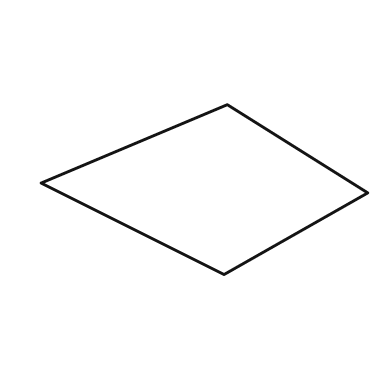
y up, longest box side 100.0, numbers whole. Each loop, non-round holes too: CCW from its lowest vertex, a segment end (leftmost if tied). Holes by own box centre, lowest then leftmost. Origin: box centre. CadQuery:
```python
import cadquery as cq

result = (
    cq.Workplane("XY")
    .moveTo(6.0, -26.0)
    .lineTo(50.0, -1.0)
    .lineTo(7.0, 26.0)
    .lineTo(-50.0, 2.0)
    .close()
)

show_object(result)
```